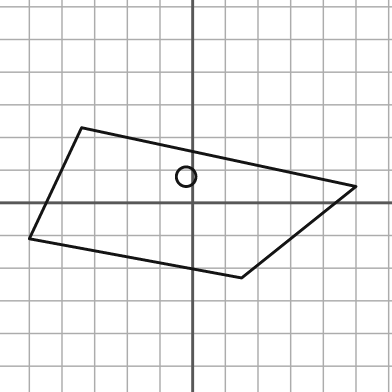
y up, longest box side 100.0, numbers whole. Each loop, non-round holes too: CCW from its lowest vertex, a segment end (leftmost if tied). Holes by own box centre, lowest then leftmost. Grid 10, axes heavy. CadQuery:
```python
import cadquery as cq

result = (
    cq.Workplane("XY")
    .moveTo(15.0, -23.0)
    .lineTo(50.0, 5.0)
    .lineTo(-34.0, 23.0)
    .lineTo(-50.0, -11.0)
    .close()
    .moveTo(-2.0, 8.0)
    .circle(3.0)
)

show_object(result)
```